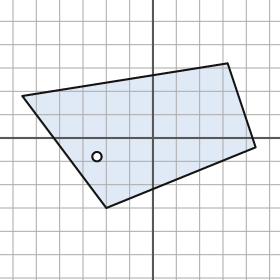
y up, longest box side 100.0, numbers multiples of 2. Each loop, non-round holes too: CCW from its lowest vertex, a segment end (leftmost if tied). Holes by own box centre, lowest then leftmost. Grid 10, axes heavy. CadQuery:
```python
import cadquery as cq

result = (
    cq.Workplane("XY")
    .moveTo(-20.0, -30.0)
    .lineTo(44.0, -4.0)
    .lineTo(32.0, 32.0)
    .lineTo(-56.0, 18.0)
    .close()
    .moveTo(-24.0, -8.0)
    .circle(2.0)
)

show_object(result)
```